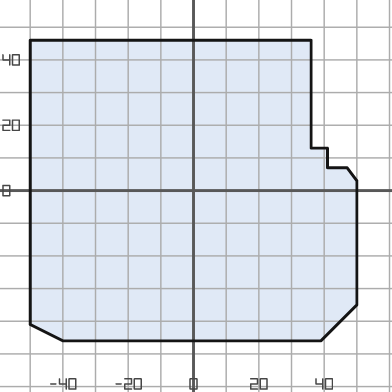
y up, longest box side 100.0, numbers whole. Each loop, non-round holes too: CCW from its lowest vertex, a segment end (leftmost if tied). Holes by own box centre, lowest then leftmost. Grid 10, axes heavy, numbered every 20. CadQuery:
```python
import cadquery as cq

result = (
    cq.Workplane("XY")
    .moveTo(-40.0, -46.0)
    .lineTo(39.0, -46.0)
    .lineTo(50.0, -35.0)
    .lineTo(50.0, 3.0)
    .lineTo(47.0, 7.0)
    .lineTo(41.0, 7.0)
    .lineTo(41.0, 13.0)
    .lineTo(36.0, 13.0)
    .lineTo(36.0, 46.0)
    .lineTo(-50.0, 46.0)
    .lineTo(-50.0, -41.0)
    .close()
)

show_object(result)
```